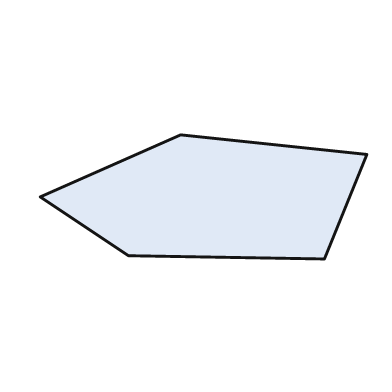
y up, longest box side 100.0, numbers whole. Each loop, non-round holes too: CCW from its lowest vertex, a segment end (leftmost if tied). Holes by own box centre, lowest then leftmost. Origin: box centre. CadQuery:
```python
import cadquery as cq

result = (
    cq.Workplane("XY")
    .moveTo(37.0, -19.0)
    .lineTo(50.0, 13.0)
    .lineTo(-7.0, 19.0)
    .lineTo(-50.0, 0.0)
    .lineTo(-23.0, -18.0)
    .close()
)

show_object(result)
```